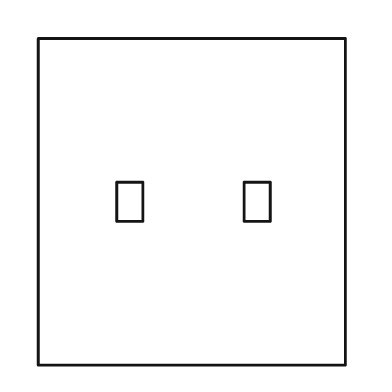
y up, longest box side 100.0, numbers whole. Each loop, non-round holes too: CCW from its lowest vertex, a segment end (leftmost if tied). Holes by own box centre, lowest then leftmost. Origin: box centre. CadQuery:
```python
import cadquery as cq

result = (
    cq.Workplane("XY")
    .moveTo(-47.0, -50.0)
    .lineTo(47.0, -50.0)
    .lineTo(47.0, 50.0)
    .lineTo(-47.0, 50.0)
    .close()
    .moveTo(-23.0, -6.0)
    .lineTo(-15.0, -6.0)
    .lineTo(-15.0, 6.0)
    .lineTo(-23.0, 6.0)
    .close()
    .moveTo(16.0, -6.0)
    .lineTo(24.0, -6.0)
    .lineTo(24.0, 6.0)
    .lineTo(16.0, 6.0)
    .close()
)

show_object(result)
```